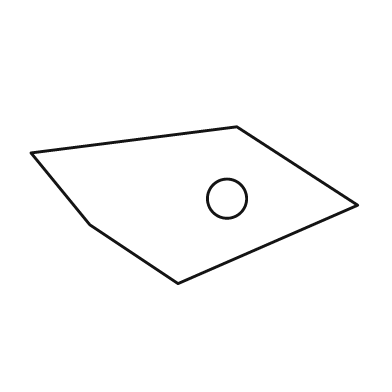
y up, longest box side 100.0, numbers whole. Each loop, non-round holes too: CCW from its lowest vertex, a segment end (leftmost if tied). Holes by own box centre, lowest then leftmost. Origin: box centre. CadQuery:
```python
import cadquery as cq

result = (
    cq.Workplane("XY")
    .moveTo(-5.0, -24.0)
    .lineTo(50.0, 0.0)
    .lineTo(13.0, 24.0)
    .lineTo(-50.0, 16.0)
    .lineTo(-32.0, -6.0)
    .close()
    .moveTo(10.0, 2.0)
    .circle(6.0)
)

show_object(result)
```